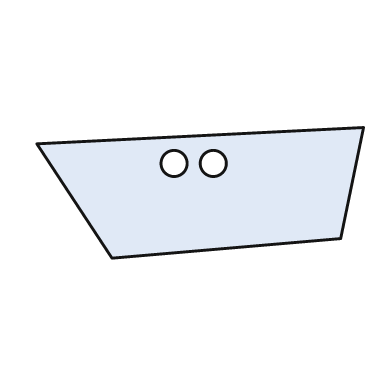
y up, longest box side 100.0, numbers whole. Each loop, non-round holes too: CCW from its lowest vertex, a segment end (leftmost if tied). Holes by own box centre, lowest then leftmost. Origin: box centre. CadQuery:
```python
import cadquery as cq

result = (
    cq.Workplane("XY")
    .moveTo(-27.0, -20.0)
    .lineTo(43.0, -14.0)
    .lineTo(50.0, 20.0)
    .lineTo(-50.0, 15.0)
    .close()
    .moveTo(-8.0, 9.0)
    .circle(4.0)
    .moveTo(4.0, 9.0)
    .circle(4.0)
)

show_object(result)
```